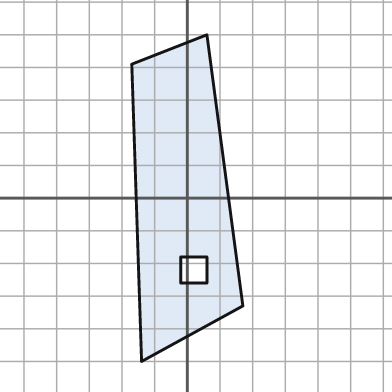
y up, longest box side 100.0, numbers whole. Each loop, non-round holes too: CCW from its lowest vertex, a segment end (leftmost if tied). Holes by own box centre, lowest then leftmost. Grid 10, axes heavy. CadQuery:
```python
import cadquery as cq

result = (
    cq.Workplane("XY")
    .moveTo(-14.0, -50.0)
    .lineTo(17.0, -33.0)
    .lineTo(6.0, 50.0)
    .lineTo(-17.0, 41.0)
    .close()
    .moveTo(-2.0, -26.0)
    .lineTo(6.0, -26.0)
    .lineTo(6.0, -18.0)
    .lineTo(-2.0, -18.0)
    .close()
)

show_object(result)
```